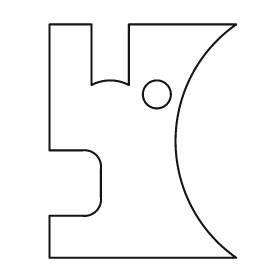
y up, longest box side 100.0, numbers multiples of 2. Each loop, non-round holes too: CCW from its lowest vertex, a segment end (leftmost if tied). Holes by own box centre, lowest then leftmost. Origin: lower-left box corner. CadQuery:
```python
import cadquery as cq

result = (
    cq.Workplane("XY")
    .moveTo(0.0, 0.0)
    .lineTo(80.0, 0.0)
    .threePointArc((54.0, 50.0), (80.0, 100.0))
    .lineTo(34.0, 100.0)
    .lineTo(34.0, 74.0)
    .threePointArc((26.0, 76.0), (18.0, 74.0))
    .lineTo(18.0, 100.0)
    .lineTo(0.0, 100.0)
    .lineTo(0.0, 46.0)
    .lineTo(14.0, 46.0)
    .threePointArc((20.0, 44.0), (22.0, 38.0))
    .lineTo(22.0, 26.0)
    .threePointArc((20.0, 20.0), (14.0, 18.0))
    .lineTo(0.0, 18.0)
    .close()
    .moveTo(46.0, 70.0)
    .circle(6.0)
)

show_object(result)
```